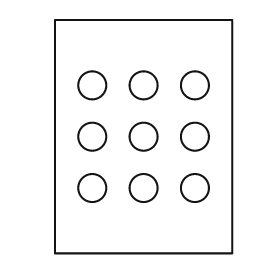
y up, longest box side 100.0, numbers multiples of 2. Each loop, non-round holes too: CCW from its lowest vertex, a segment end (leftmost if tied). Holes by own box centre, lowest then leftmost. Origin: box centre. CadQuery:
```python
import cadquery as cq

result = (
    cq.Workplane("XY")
    .moveTo(-38.0, -50.0)
    .lineTo(38.0, -50.0)
    .lineTo(38.0, 50.0)
    .lineTo(-38.0, 50.0)
    .close()
    .moveTo(-22.0, -22.0)
    .circle(6.0)
    .moveTo(0.0, -22.0)
    .circle(6.0)
    .moveTo(22.0, -22.0)
    .circle(6.0)
    .moveTo(-22.0, 0.0)
    .circle(6.0)
    .moveTo(0.0, 0.0)
    .circle(6.0)
    .moveTo(22.0, 0.0)
    .circle(6.0)
    .moveTo(-22.0, 22.0)
    .circle(6.0)
    .moveTo(0.0, 22.0)
    .circle(6.0)
    .moveTo(22.0, 22.0)
    .circle(6.0)
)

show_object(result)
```